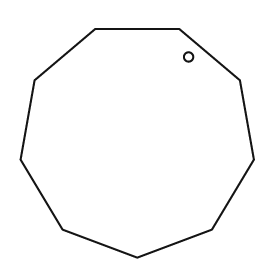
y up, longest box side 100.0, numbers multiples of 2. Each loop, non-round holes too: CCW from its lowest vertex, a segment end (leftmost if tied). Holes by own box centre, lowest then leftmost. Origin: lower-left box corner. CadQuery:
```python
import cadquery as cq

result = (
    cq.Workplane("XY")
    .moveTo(50.0, 0.0)
    .lineTo(82.0, 12.0)
    .lineTo(100.0, 42.0)
    .lineTo(94.0, 76.0)
    .lineTo(68.0, 98.0)
    .lineTo(32.0, 98.0)
    .lineTo(6.0, 76.0)
    .lineTo(0.0, 42.0)
    .lineTo(18.0, 12.0)
    .close()
    .moveTo(72.0, 86.0)
    .circle(2.0)
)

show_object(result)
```